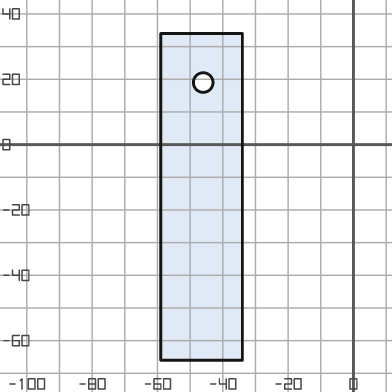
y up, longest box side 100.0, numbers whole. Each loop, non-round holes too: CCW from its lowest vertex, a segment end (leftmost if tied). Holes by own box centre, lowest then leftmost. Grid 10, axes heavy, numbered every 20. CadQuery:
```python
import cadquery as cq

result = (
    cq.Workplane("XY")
    .moveTo(-59.0, -66.0)
    .lineTo(-34.0, -66.0)
    .lineTo(-34.0, 34.0)
    .lineTo(-59.0, 34.0)
    .close()
    .moveTo(-46.0, 19.0)
    .circle(3.0)
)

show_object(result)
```